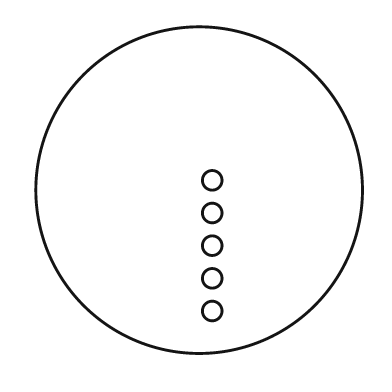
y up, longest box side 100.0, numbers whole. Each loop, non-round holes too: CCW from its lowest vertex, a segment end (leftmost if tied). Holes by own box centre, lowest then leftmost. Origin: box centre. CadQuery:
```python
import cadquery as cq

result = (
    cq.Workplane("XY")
    .moveTo(0.0, 0.0)
    .circle(50.0)
    .moveTo(4.0, -37.0)
    .circle(3.0)
    .moveTo(4.0, -27.0)
    .circle(3.0)
    .moveTo(4.0, -17.0)
    .circle(3.0)
    .moveTo(4.0, -7.0)
    .circle(3.0)
    .moveTo(4.0, 3.0)
    .circle(3.0)
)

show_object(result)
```